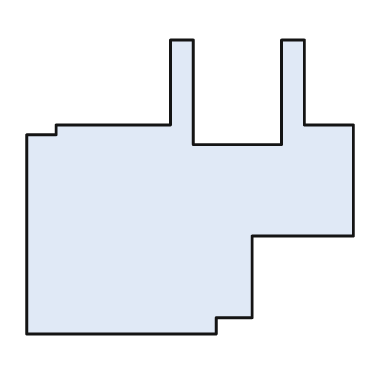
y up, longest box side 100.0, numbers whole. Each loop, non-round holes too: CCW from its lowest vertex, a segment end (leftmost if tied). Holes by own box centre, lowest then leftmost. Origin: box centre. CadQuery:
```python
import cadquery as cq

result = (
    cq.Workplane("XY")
    .moveTo(-50.0, -45.0)
    .lineTo(8.0, -45.0)
    .lineTo(8.0, -40.0)
    .lineTo(19.0, -40.0)
    .lineTo(19.0, -15.0)
    .lineTo(50.0, -15.0)
    .lineTo(50.0, 19.0)
    .lineTo(35.0, 19.0)
    .lineTo(35.0, 45.0)
    .lineTo(28.0, 45.0)
    .lineTo(28.0, 13.0)
    .lineTo(1.0, 13.0)
    .lineTo(1.0, 45.0)
    .lineTo(-6.0, 45.0)
    .lineTo(-6.0, 19.0)
    .lineTo(-41.0, 19.0)
    .lineTo(-41.0, 16.0)
    .lineTo(-50.0, 16.0)
    .close()
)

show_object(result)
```